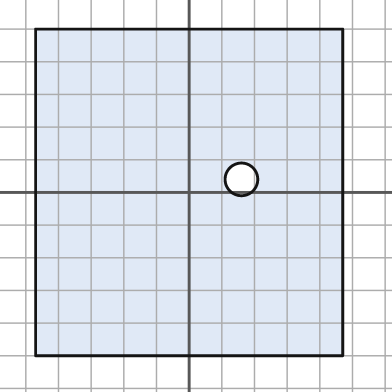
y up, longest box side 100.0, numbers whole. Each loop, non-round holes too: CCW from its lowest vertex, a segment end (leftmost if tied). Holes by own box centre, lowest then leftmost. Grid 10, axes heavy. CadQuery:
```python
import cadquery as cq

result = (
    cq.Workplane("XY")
    .moveTo(-47.0, -50.0)
    .lineTo(47.0, -50.0)
    .lineTo(47.0, 50.0)
    .lineTo(-47.0, 50.0)
    .close()
    .moveTo(16.0, 4.0)
    .circle(5.0)
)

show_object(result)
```